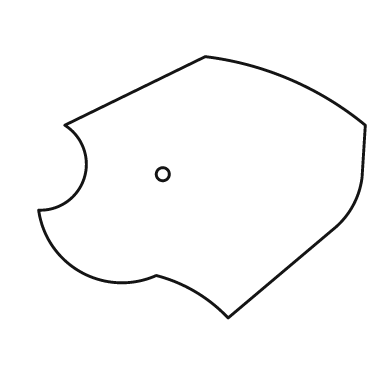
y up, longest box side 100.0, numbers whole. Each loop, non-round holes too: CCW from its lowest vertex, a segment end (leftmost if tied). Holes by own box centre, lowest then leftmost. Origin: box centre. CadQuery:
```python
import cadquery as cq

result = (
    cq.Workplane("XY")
    .moveTo(8.0, -40.0)
    .lineTo(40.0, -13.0)
    .threePointArc((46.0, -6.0), (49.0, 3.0))
    .lineTo(50.0, 19.0)
    .threePointArc((27.0, 33.0), (1.0, 40.0))
    .lineTo(-42.0, 19.0)
    .threePointArc((-36.0, 3.0), (-50.0, -7.0))
    .threePointArc((-37.0, -26.0), (-14.0, -27.0))
    .threePointArc((-2.0, -32.0), (8.0, -40.0))
    .close()
    .moveTo(-12.0, 4.0)
    .circle(2.0)
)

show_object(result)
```